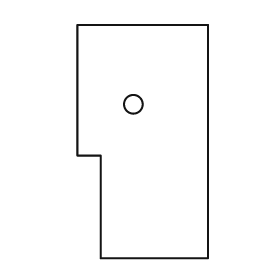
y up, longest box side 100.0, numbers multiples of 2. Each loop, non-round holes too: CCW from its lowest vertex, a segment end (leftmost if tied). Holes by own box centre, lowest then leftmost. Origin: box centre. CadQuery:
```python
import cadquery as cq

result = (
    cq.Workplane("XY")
    .moveTo(-18.0, -50.0)
    .lineTo(28.0, -50.0)
    .lineTo(28.0, 50.0)
    .lineTo(-28.0, 50.0)
    .lineTo(-28.0, -6.0)
    .lineTo(-18.0, -6.0)
    .close()
    .moveTo(-4.0, 16.0)
    .circle(4.0)
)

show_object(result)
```